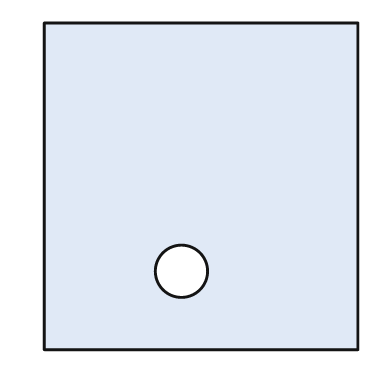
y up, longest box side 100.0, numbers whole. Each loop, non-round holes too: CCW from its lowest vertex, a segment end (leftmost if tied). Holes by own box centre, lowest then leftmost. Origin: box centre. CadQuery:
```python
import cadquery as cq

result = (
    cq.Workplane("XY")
    .moveTo(-48.0, -50.0)
    .lineTo(48.0, -50.0)
    .lineTo(48.0, 50.0)
    .lineTo(-48.0, 50.0)
    .close()
    .moveTo(-6.0, -26.0)
    .circle(8.0)
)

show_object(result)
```